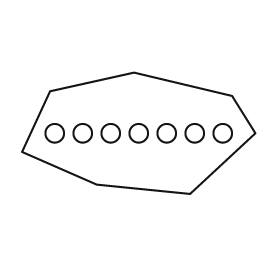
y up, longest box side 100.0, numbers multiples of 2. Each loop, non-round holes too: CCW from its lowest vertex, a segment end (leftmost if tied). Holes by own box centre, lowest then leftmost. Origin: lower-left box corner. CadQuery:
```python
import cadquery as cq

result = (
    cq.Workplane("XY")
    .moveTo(72.0, 0.0)
    .lineTo(100.0, 26.0)
    .lineTo(90.0, 42.0)
    .lineTo(48.0, 52.0)
    .lineTo(12.0, 44.0)
    .lineTo(0.0, 18.0)
    .lineTo(32.0, 4.0)
    .close()
    .moveTo(14.0, 26.0)
    .circle(4.0)
    .moveTo(26.0, 26.0)
    .circle(4.0)
    .moveTo(38.0, 26.0)
    .circle(4.0)
    .moveTo(50.0, 26.0)
    .circle(4.0)
    .moveTo(62.0, 26.0)
    .circle(4.0)
    .moveTo(74.0, 26.0)
    .circle(4.0)
    .moveTo(86.0, 26.0)
    .circle(4.0)
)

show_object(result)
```